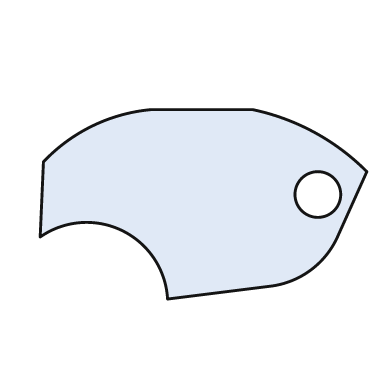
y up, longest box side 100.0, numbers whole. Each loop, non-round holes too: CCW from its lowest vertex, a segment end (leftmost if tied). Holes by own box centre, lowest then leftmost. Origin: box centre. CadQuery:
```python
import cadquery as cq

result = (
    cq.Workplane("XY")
    .moveTo(-11.0, -29.0)
    .lineTo(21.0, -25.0)
    .threePointArc((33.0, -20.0), (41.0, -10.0))
    .lineTo(50.0, 10.0)
    .threePointArc((34.0, 22.0), (15.0, 29.0))
    .lineTo(-16.0, 29.0)
    .threePointArc((-34.0, 24.0), (-49.0, 13.0))
    .lineTo(-50.0, -10.0)
    .threePointArc((-25.0, -8.0), (-11.0, -29.0))
    .close()
    .moveTo(35.0, 3.0)
    .circle(7.0)
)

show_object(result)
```